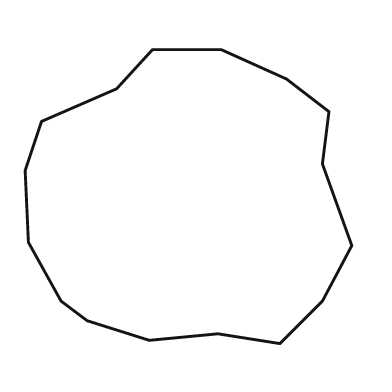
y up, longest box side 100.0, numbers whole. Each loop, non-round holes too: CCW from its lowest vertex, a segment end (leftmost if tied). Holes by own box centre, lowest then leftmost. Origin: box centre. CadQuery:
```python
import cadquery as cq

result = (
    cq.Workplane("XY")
    .moveTo(28.0, -45.0)
    .lineTo(41.0, -32.0)
    .lineTo(50.0, -15.0)
    .lineTo(41.0, 10.0)
    .lineTo(43.0, 26.0)
    .lineTo(30.0, 36.0)
    .lineTo(10.0, 45.0)
    .lineTo(-11.0, 45.0)
    .lineTo(-22.0, 33.0)
    .lineTo(-45.0, 23.0)
    .lineTo(-50.0, 8.0)
    .lineTo(-49.0, -14.0)
    .lineTo(-39.0, -32.0)
    .lineTo(-31.0, -38.0)
    .lineTo(-12.0, -44.0)
    .lineTo(9.0, -42.0)
    .close()
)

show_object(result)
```